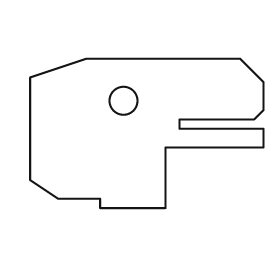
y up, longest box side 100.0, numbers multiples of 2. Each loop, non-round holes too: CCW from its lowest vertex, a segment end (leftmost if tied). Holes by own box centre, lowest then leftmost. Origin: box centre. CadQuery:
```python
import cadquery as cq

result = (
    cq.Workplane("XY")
    .moveTo(-20.0, -32.0)
    .lineTo(8.0, -32.0)
    .lineTo(8.0, -6.0)
    .lineTo(50.0, -6.0)
    .lineTo(50.0, 2.0)
    .lineTo(14.0, 2.0)
    .lineTo(14.0, 6.0)
    .lineTo(46.0, 6.0)
    .lineTo(50.0, 10.0)
    .lineTo(50.0, 22.0)
    .lineTo(40.0, 32.0)
    .lineTo(-26.0, 32.0)
    .lineTo(-50.0, 24.0)
    .lineTo(-50.0, -20.0)
    .lineTo(-38.0, -28.0)
    .lineTo(-20.0, -28.0)
    .close()
    .moveTo(-10.0, 14.0)
    .circle(6.0)
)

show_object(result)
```